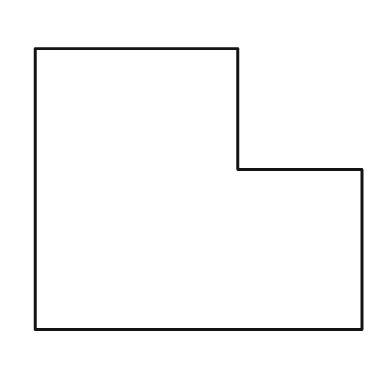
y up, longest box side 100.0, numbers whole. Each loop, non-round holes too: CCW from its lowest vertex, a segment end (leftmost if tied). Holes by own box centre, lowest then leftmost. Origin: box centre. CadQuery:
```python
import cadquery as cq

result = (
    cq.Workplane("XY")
    .moveTo(-50.0, -43.0)
    .lineTo(50.0, -43.0)
    .lineTo(50.0, 6.0)
    .lineTo(12.0, 6.0)
    .lineTo(12.0, 43.0)
    .lineTo(-50.0, 43.0)
    .close()
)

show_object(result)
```